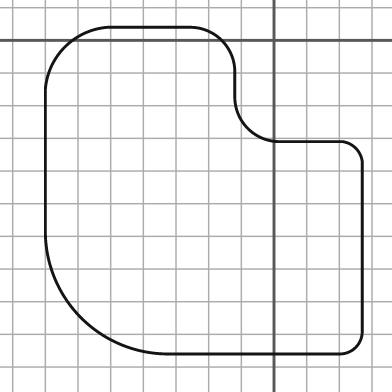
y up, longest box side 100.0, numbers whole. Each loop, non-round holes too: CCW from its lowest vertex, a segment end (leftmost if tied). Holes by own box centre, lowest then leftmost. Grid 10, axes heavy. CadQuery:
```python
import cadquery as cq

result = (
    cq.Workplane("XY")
    .moveTo(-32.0, -96.0)
    .lineTo(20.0, -96.0)
    .threePointArc((25.0, -94.0), (27.0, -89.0))
    .lineTo(27.0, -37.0)
    .threePointArc((25.0, -33.0), (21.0, -31.0))
    .lineTo(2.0, -31.0)
    .threePointArc((-8.0, -27.0), (-12.0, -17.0))
    .lineTo(-12.0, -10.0)
    .threePointArc((-16.0, 0.0), (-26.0, 4.0))
    .lineTo(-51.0, 4.0)
    .threePointArc((-64.0, -2.0), (-70.0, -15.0))
    .lineTo(-70.0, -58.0)
    .threePointArc((-59.0, -85.0), (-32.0, -96.0))
    .close()
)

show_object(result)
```